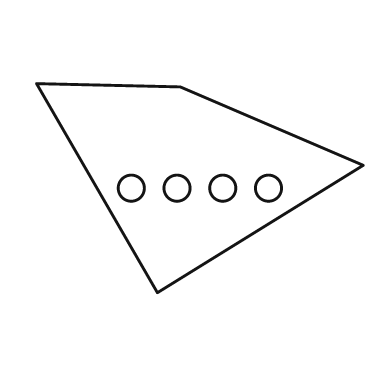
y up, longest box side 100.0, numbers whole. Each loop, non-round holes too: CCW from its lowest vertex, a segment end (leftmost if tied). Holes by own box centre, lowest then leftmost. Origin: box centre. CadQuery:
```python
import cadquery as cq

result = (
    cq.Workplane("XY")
    .moveTo(-13.0, -32.0)
    .lineTo(50.0, 7.0)
    .lineTo(-6.0, 31.0)
    .lineTo(-50.0, 32.0)
    .close()
    .moveTo(-21.0, 0.0)
    .circle(4.0)
    .moveTo(-7.0, 0.0)
    .circle(4.0)
    .moveTo(7.0, 0.0)
    .circle(4.0)
    .moveTo(21.0, 0.0)
    .circle(4.0)
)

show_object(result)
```